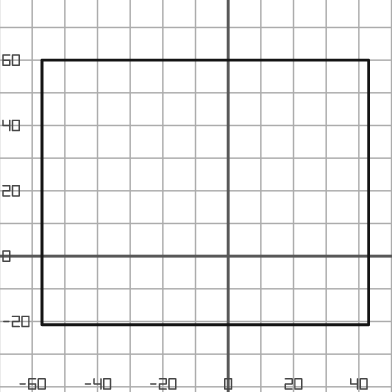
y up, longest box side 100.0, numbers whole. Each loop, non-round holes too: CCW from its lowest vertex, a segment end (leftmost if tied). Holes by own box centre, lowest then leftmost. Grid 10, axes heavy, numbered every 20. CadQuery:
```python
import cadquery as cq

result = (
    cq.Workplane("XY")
    .moveTo(-57.0, -21.0)
    .lineTo(43.0, -21.0)
    .lineTo(43.0, 60.0)
    .lineTo(-57.0, 60.0)
    .close()
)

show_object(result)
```